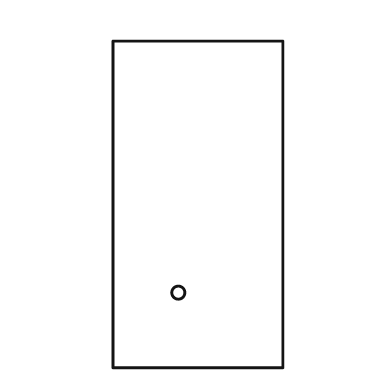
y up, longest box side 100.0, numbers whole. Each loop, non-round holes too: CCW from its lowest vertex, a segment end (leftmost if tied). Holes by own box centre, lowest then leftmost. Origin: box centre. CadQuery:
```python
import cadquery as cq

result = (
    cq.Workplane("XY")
    .moveTo(-26.0, -50.0)
    .lineTo(26.0, -50.0)
    .lineTo(26.0, 50.0)
    .lineTo(-26.0, 50.0)
    .close()
    .moveTo(-6.0, -27.0)
    .circle(2.0)
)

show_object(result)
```